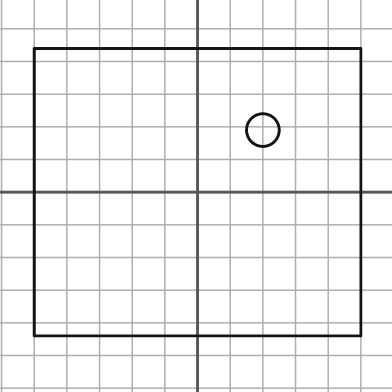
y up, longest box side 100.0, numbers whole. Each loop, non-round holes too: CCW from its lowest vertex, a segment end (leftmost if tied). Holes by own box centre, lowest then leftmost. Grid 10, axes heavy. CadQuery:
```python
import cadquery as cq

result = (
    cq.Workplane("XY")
    .moveTo(-50.0, -44.0)
    .lineTo(50.0, -44.0)
    .lineTo(50.0, 44.0)
    .lineTo(-50.0, 44.0)
    .close()
    .moveTo(20.0, 19.0)
    .circle(5.0)
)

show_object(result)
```